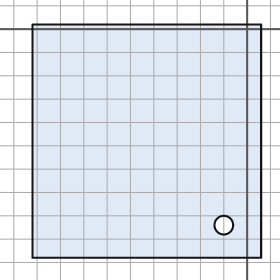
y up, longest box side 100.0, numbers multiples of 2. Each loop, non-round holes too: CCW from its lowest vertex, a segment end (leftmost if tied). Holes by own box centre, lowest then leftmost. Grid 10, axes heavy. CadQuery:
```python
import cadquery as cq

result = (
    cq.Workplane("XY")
    .moveTo(-92.0, -98.0)
    .lineTo(6.0, -98.0)
    .lineTo(6.0, 2.0)
    .lineTo(-92.0, 2.0)
    .close()
    .moveTo(-10.0, -84.0)
    .circle(4.0)
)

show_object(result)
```